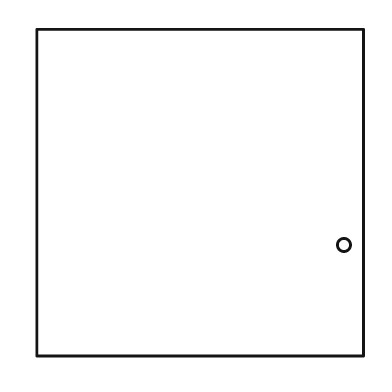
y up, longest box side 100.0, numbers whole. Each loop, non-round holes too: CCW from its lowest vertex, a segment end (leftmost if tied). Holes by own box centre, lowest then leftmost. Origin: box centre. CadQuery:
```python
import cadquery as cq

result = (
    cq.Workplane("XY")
    .moveTo(-50.0, -50.0)
    .lineTo(50.0, -50.0)
    .lineTo(50.0, 50.0)
    .lineTo(-50.0, 50.0)
    .close()
    .moveTo(44.0, -16.0)
    .circle(2.0)
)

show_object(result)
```